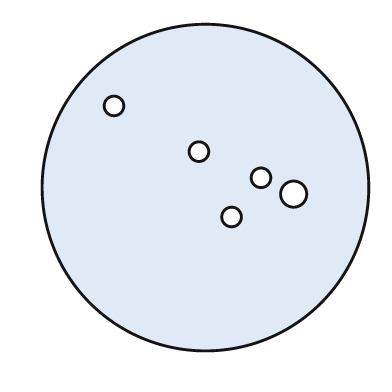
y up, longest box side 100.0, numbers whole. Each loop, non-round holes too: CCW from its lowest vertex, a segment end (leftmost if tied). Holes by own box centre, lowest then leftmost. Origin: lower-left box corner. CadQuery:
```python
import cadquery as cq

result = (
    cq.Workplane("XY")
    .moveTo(50.0, 50.0)
    .circle(50.0)
    .moveTo(58.0, 41.0)
    .circle(3.0)
    .moveTo(77.0, 48.0)
    .circle(4.0)
    .moveTo(67.0, 53.0)
    .circle(3.0)
    .moveTo(48.0, 61.0)
    .circle(3.0)
    .moveTo(22.0, 75.0)
    .circle(3.0)
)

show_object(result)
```